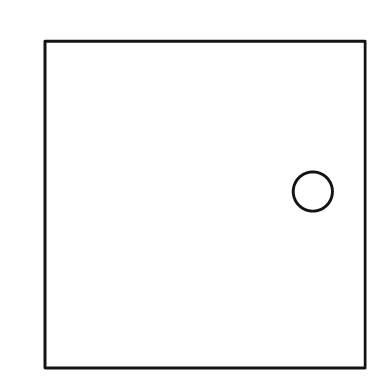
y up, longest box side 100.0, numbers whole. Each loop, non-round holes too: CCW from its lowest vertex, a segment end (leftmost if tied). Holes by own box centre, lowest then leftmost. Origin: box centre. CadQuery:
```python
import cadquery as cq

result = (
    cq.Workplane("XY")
    .moveTo(-49.0, -50.0)
    .lineTo(49.0, -50.0)
    .lineTo(49.0, 50.0)
    .lineTo(-49.0, 50.0)
    .close()
    .moveTo(33.0, 4.0)
    .circle(6.0)
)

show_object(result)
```